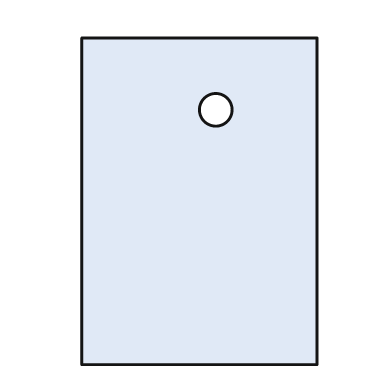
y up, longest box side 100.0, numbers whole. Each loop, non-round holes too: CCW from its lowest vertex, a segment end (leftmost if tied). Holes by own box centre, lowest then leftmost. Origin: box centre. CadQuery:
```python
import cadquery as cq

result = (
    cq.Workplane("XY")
    .moveTo(-36.0, -50.0)
    .lineTo(36.0, -50.0)
    .lineTo(36.0, 50.0)
    .lineTo(-36.0, 50.0)
    .close()
    .moveTo(5.0, 28.0)
    .circle(5.0)
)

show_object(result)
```